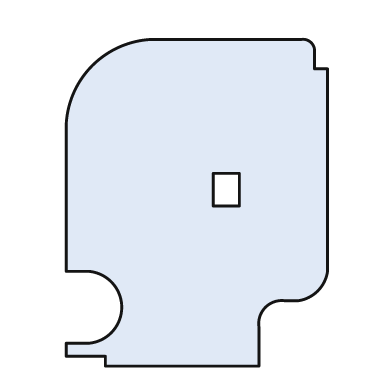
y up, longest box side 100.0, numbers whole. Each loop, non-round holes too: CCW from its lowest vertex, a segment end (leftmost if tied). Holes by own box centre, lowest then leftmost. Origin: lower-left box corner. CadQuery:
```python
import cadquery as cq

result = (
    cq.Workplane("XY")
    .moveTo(12.0, 0.0)
    .lineTo(59.0, 0.0)
    .lineTo(59.0, 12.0)
    .threePointArc((61.0, 18.0), (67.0, 20.0))
    .lineTo(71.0, 20.0)
    .threePointArc((77.0, 23.0), (80.0, 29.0))
    .lineTo(80.0, 91.0)
    .lineTo(76.0, 91.0)
    .lineTo(76.0, 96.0)
    .threePointArc((75.0, 99.0), (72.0, 100.0))
    .lineTo(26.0, 100.0)
    .threePointArc((8.0, 92.0), (0.0, 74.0))
    .lineTo(0.0, 29.0)
    .lineTo(7.0, 29.0)
    .threePointArc((17.0, 18.0), (7.0, 7.0))
    .lineTo(0.0, 7.0)
    .lineTo(0.0, 3.0)
    .lineTo(12.0, 3.0)
    .close()
    .moveTo(45.0, 49.0)
    .lineTo(53.0, 49.0)
    .lineTo(53.0, 59.0)
    .lineTo(45.0, 59.0)
    .close()
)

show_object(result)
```